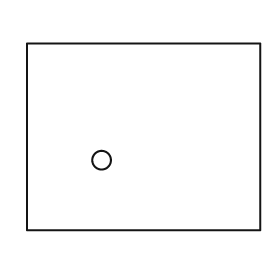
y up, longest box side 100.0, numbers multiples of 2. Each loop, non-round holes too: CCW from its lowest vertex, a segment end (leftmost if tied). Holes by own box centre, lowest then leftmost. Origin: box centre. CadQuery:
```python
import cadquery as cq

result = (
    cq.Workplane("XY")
    .moveTo(-50.0, -40.0)
    .lineTo(50.0, -40.0)
    .lineTo(50.0, 40.0)
    .lineTo(-50.0, 40.0)
    .close()
    .moveTo(-18.0, -10.0)
    .circle(4.0)
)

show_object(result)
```